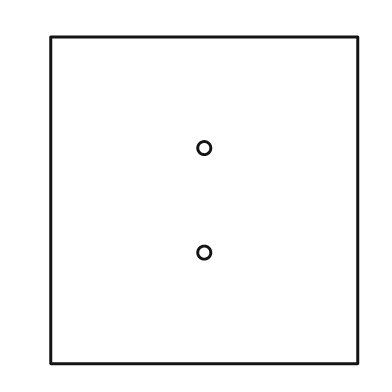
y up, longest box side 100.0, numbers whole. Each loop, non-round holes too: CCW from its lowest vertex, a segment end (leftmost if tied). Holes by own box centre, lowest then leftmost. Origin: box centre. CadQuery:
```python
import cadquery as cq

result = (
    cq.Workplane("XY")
    .moveTo(-47.0, -50.0)
    .lineTo(47.0, -50.0)
    .lineTo(47.0, 50.0)
    .lineTo(-47.0, 50.0)
    .close()
    .moveTo(0.0, -16.0)
    .circle(2.0)
    .moveTo(0.0, 16.0)
    .circle(2.0)
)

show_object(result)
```